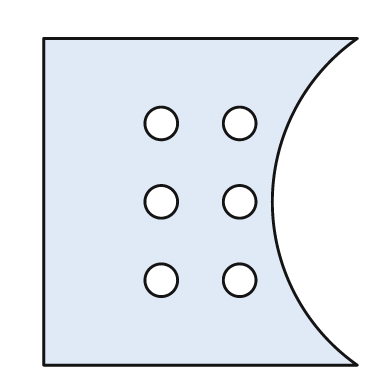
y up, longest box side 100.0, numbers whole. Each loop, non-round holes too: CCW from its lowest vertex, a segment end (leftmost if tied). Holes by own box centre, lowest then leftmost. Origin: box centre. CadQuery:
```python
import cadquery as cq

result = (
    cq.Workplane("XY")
    .moveTo(-48.0, -50.0)
    .lineTo(48.0, -50.0)
    .threePointArc((22.0, 0.0), (48.0, 50.0))
    .lineTo(-48.0, 50.0)
    .close()
    .moveTo(-12.0, -24.0)
    .circle(5.0)
    .moveTo(12.0, -24.0)
    .circle(5.0)
    .moveTo(-12.0, 0.0)
    .circle(5.0)
    .moveTo(12.0, 0.0)
    .circle(5.0)
    .moveTo(-12.0, 24.0)
    .circle(5.0)
    .moveTo(12.0, 24.0)
    .circle(5.0)
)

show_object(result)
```